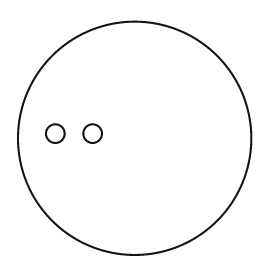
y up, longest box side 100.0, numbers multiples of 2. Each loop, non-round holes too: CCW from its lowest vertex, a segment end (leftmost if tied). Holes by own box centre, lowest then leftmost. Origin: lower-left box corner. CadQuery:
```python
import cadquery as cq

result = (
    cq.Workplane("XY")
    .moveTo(50.0, 50.0)
    .circle(50.0)
    .moveTo(16.0, 52.0)
    .circle(4.0)
    .moveTo(32.0, 52.0)
    .circle(4.0)
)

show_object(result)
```